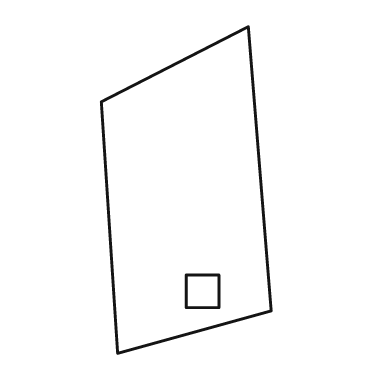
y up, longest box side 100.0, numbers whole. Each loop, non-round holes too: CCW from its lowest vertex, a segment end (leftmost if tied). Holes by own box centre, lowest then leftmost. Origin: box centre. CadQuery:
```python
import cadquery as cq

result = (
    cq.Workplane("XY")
    .moveTo(-21.0, -50.0)
    .lineTo(26.0, -37.0)
    .lineTo(19.0, 50.0)
    .lineTo(-26.0, 27.0)
    .close()
    .moveTo(0.0, -36.0)
    .lineTo(10.0, -36.0)
    .lineTo(10.0, -26.0)
    .lineTo(0.0, -26.0)
    .close()
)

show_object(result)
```